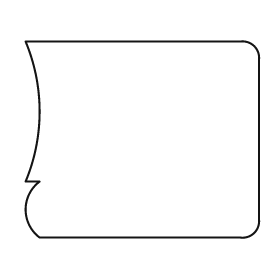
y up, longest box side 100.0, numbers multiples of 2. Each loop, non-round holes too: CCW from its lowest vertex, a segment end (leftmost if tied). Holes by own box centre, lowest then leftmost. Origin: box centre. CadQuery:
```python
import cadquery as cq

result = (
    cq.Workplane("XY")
    .moveTo(-44.0, -42.0)
    .lineTo(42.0, -42.0)
    .threePointArc((48.0, -40.0), (50.0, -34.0))
    .lineTo(50.0, 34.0)
    .threePointArc((48.0, 40.0), (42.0, 42.0))
    .lineTo(-50.0, 42.0)
    .threePointArc((-44.0, 12.0), (-50.0, -18.0))
    .lineTo(-44.0, -18.0)
    .threePointArc((-50.0, -30.0), (-44.0, -42.0))
    .close()
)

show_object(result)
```